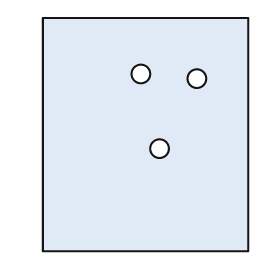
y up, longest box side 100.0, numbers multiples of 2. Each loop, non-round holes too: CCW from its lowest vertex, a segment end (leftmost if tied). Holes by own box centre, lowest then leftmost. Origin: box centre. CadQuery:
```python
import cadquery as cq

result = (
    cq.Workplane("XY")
    .moveTo(-44.0, -50.0)
    .lineTo(44.0, -50.0)
    .lineTo(44.0, 50.0)
    .lineTo(-44.0, 50.0)
    .close()
    .moveTo(6.0, -6.0)
    .circle(4.0)
    .moveTo(22.0, 24.0)
    .circle(4.0)
    .moveTo(-2.0, 26.0)
    .circle(4.0)
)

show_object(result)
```